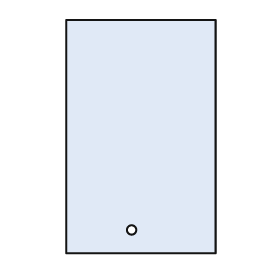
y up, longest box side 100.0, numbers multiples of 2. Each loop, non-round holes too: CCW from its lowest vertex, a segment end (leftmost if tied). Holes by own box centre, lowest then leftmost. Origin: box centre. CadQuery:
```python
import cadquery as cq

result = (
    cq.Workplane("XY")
    .moveTo(-32.0, -50.0)
    .lineTo(32.0, -50.0)
    .lineTo(32.0, 50.0)
    .lineTo(-32.0, 50.0)
    .close()
    .moveTo(-4.0, -40.0)
    .circle(2.0)
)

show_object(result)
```